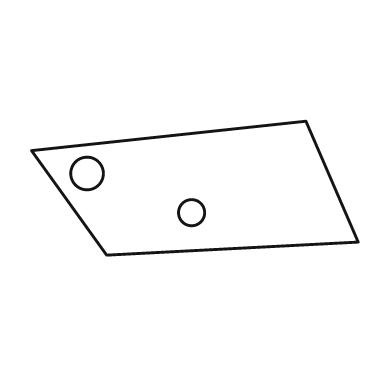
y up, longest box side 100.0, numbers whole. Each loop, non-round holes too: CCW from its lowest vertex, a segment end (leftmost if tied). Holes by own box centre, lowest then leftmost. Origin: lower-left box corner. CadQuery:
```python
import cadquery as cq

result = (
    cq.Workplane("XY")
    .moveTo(23.0, 0.0)
    .lineTo(100.0, 4.0)
    .lineTo(84.0, 41.0)
    .lineTo(0.0, 32.0)
    .close()
    .moveTo(49.0, 13.0)
    .circle(4.0)
    .moveTo(17.0, 25.0)
    .circle(5.0)
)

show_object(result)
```